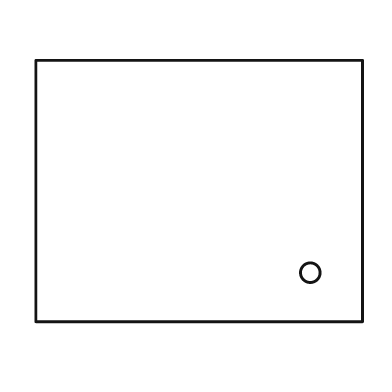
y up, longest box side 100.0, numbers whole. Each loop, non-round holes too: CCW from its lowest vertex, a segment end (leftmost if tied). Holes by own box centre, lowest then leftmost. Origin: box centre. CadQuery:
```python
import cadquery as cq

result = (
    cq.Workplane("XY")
    .moveTo(-50.0, -40.0)
    .lineTo(50.0, -40.0)
    .lineTo(50.0, 40.0)
    .lineTo(-50.0, 40.0)
    .close()
    .moveTo(34.0, -25.0)
    .circle(3.0)
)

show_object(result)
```